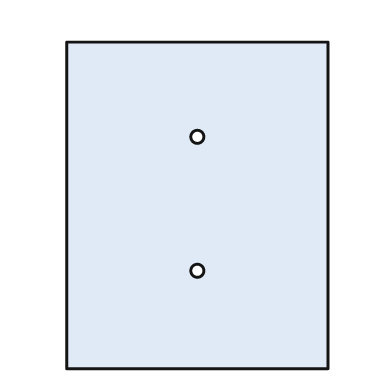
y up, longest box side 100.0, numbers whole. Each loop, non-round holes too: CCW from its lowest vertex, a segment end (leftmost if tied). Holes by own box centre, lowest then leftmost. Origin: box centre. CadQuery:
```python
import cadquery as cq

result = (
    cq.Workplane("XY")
    .moveTo(-40.0, -50.0)
    .lineTo(40.0, -50.0)
    .lineTo(40.0, 50.0)
    .lineTo(-40.0, 50.0)
    .close()
    .moveTo(0.0, -20.0)
    .circle(2.0)
    .moveTo(0.0, 21.0)
    .circle(2.0)
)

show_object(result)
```